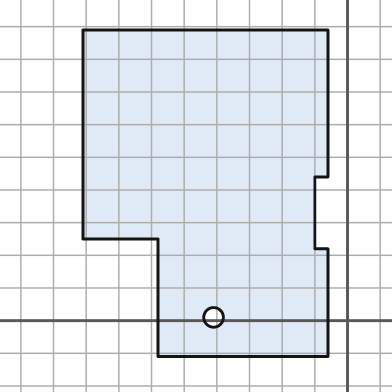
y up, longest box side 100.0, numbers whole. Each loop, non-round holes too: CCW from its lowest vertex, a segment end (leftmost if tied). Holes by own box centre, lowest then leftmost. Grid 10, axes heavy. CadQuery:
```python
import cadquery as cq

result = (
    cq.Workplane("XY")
    .moveTo(-58.0, -11.0)
    .lineTo(-6.0, -11.0)
    .lineTo(-6.0, 22.0)
    .lineTo(-10.0, 22.0)
    .lineTo(-10.0, 44.0)
    .lineTo(-6.0, 44.0)
    .lineTo(-6.0, 89.0)
    .lineTo(-81.0, 89.0)
    .lineTo(-81.0, 25.0)
    .lineTo(-58.0, 25.0)
    .close()
    .moveTo(-41.0, 1.0)
    .circle(3.0)
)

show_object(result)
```